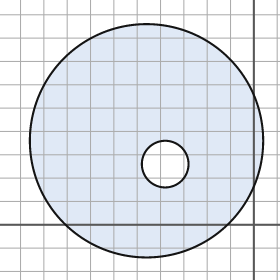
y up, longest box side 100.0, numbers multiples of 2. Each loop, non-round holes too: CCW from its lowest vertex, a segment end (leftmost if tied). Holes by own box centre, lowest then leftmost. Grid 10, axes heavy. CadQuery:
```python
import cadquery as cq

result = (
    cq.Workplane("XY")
    .moveTo(-46.0, 36.0)
    .circle(50.0)
    .moveTo(-38.0, 26.0)
    .circle(10.0)
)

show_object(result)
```